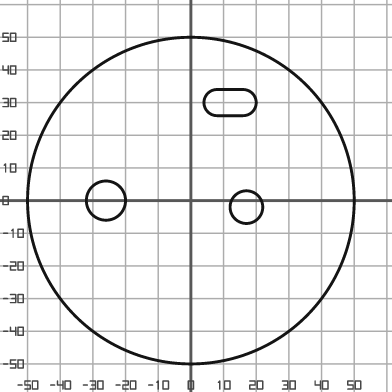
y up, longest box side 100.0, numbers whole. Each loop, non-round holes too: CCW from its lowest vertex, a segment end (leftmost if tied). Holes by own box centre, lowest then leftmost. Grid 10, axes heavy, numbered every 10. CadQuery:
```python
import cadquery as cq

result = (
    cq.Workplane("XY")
    .moveTo(0.0, 0.0)
    .circle(50.0)
    .moveTo(17.0, -2.0)
    .circle(5.0)
    .moveTo(-26.0, 0.0)
    .circle(6.0)
    .moveTo(8.0, 26.0)
    .lineTo(16.0, 26.0)
    .threePointArc((20.0, 30.0), (16.0, 34.0))
    .lineTo(8.0, 34.0)
    .threePointArc((4.0, 30.0), (8.0, 26.0))
    .close()
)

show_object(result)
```